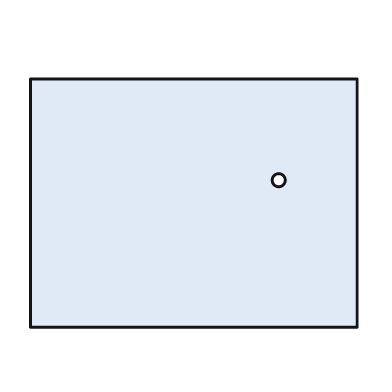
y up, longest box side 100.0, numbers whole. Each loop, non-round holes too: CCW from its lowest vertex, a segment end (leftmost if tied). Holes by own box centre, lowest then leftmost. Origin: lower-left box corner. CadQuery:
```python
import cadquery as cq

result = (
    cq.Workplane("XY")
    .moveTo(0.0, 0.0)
    .lineTo(100.0, 0.0)
    .lineTo(100.0, 76.0)
    .lineTo(0.0, 76.0)
    .close()
    .moveTo(76.0, 45.0)
    .circle(2.0)
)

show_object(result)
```